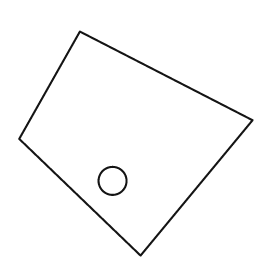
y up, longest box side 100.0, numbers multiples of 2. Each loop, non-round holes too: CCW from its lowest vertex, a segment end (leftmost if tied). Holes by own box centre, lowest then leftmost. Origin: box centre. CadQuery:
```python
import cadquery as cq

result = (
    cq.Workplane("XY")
    .moveTo(2.0, -48.0)
    .lineTo(50.0, 10.0)
    .lineTo(-24.0, 48.0)
    .lineTo(-50.0, 2.0)
    .close()
    .moveTo(-10.0, -16.0)
    .circle(6.0)
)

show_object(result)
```